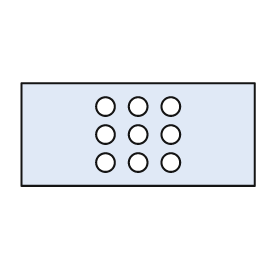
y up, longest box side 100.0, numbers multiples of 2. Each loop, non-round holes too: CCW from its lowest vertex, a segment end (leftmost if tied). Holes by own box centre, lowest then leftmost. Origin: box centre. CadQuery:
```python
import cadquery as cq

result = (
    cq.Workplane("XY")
    .moveTo(-50.0, -22.0)
    .lineTo(50.0, -22.0)
    .lineTo(50.0, 22.0)
    .lineTo(-50.0, 22.0)
    .close()
    .moveTo(-14.0, -12.0)
    .circle(4.0)
    .moveTo(0.0, -12.0)
    .circle(4.0)
    .moveTo(14.0, -12.0)
    .circle(4.0)
    .moveTo(-14.0, 0.0)
    .circle(4.0)
    .moveTo(0.0, 0.0)
    .circle(4.0)
    .moveTo(14.0, 0.0)
    .circle(4.0)
    .moveTo(-14.0, 12.0)
    .circle(4.0)
    .moveTo(0.0, 12.0)
    .circle(4.0)
    .moveTo(14.0, 12.0)
    .circle(4.0)
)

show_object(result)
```